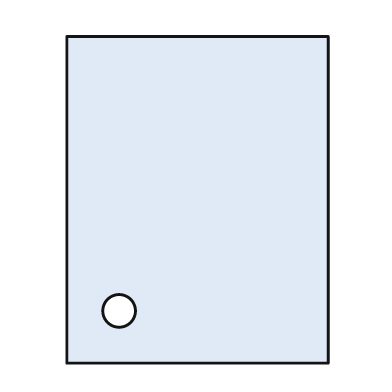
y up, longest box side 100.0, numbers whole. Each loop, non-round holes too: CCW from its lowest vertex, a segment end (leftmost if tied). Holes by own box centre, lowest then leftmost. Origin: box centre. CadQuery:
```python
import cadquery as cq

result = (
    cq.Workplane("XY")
    .moveTo(-40.0, -50.0)
    .lineTo(40.0, -50.0)
    .lineTo(40.0, 50.0)
    .lineTo(-40.0, 50.0)
    .close()
    .moveTo(-24.0, -34.0)
    .circle(5.0)
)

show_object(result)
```